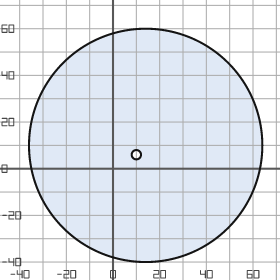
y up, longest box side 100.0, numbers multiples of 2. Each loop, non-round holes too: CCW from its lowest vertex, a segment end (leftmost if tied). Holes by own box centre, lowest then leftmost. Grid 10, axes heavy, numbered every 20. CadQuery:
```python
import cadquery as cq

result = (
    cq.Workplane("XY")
    .moveTo(14.0, 10.0)
    .circle(50.0)
    .moveTo(10.0, 6.0)
    .circle(2.0)
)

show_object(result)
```